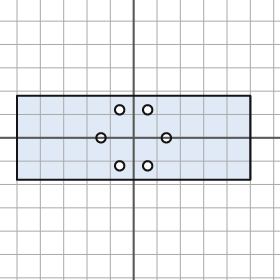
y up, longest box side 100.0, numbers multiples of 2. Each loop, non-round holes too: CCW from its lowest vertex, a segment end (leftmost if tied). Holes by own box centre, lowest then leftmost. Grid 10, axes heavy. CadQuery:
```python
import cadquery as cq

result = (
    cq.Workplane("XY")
    .moveTo(-50.0, -18.0)
    .lineTo(50.0, -18.0)
    .lineTo(50.0, 18.0)
    .lineTo(-50.0, 18.0)
    .close()
    .moveTo(-6.0, -12.0)
    .circle(2.0)
    .moveTo(6.0, -12.0)
    .circle(2.0)
    .moveTo(-14.0, 0.0)
    .circle(2.0)
    .moveTo(14.0, 0.0)
    .circle(2.0)
    .moveTo(-6.0, 12.0)
    .circle(2.0)
    .moveTo(6.0, 12.0)
    .circle(2.0)
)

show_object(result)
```